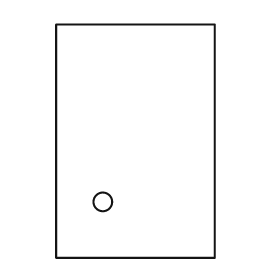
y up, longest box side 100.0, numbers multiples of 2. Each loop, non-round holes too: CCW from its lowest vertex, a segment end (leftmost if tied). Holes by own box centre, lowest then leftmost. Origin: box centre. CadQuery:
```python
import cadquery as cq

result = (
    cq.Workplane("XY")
    .moveTo(-34.0, -50.0)
    .lineTo(34.0, -50.0)
    .lineTo(34.0, 50.0)
    .lineTo(-34.0, 50.0)
    .close()
    .moveTo(-14.0, -26.0)
    .circle(4.0)
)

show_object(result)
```